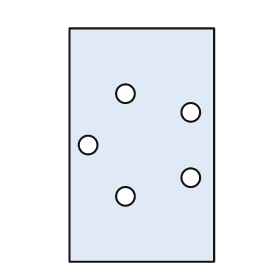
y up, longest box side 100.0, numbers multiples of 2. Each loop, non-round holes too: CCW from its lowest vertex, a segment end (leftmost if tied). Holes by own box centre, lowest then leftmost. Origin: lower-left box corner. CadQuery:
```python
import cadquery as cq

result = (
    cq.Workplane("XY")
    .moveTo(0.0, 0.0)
    .lineTo(62.0, 0.0)
    .lineTo(62.0, 100.0)
    .lineTo(0.0, 100.0)
    .close()
    .moveTo(24.0, 28.0)
    .circle(4.0)
    .moveTo(52.0, 36.0)
    .circle(4.0)
    .moveTo(8.0, 50.0)
    .circle(4.0)
    .moveTo(52.0, 64.0)
    .circle(4.0)
    .moveTo(24.0, 72.0)
    .circle(4.0)
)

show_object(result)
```